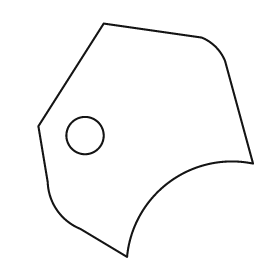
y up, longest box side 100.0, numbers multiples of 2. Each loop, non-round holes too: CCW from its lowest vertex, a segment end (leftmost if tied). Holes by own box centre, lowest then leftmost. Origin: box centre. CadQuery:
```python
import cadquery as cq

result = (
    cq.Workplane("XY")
    .moveTo(-8.0, -50.0)
    .threePointArc((10.0, -18.0), (46.0, -10.0))
    .lineTo(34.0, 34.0)
    .threePointArc((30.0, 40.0), (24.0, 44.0))
    .lineTo(-18.0, 50.0)
    .lineTo(-46.0, 6.0)
    .lineTo(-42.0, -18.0)
    .threePointArc((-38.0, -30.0), (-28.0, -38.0))
    .close()
    .moveTo(-26.0, 2.0)
    .circle(8.0)
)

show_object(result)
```